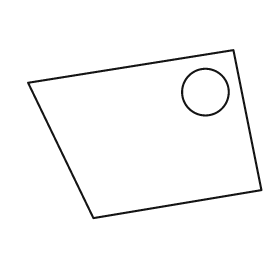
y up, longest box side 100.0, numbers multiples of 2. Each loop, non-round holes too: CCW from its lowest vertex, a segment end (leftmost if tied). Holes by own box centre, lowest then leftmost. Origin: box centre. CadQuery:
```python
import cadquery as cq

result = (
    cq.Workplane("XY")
    .moveTo(-22.0, -36.0)
    .lineTo(50.0, -24.0)
    .lineTo(38.0, 36.0)
    .lineTo(-50.0, 22.0)
    .close()
    .moveTo(26.0, 18.0)
    .circle(10.0)
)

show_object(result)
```